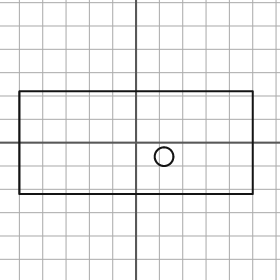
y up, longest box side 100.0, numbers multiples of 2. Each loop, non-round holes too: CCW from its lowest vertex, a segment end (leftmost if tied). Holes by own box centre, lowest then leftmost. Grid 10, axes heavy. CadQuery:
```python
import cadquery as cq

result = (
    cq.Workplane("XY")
    .moveTo(-50.0, -22.0)
    .lineTo(50.0, -22.0)
    .lineTo(50.0, 22.0)
    .lineTo(-50.0, 22.0)
    .close()
    .moveTo(12.0, -6.0)
    .circle(4.0)
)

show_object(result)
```